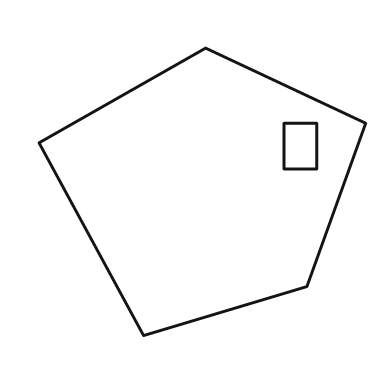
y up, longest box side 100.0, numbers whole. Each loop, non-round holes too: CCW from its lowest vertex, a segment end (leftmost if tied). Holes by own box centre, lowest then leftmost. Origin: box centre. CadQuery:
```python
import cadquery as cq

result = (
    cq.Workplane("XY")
    .moveTo(-18.0, -44.0)
    .lineTo(32.0, -29.0)
    .lineTo(50.0, 21.0)
    .lineTo(1.0, 44.0)
    .lineTo(-50.0, 15.0)
    .close()
    .moveTo(25.0, 7.0)
    .lineTo(35.0, 7.0)
    .lineTo(35.0, 21.0)
    .lineTo(25.0, 21.0)
    .close()
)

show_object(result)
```